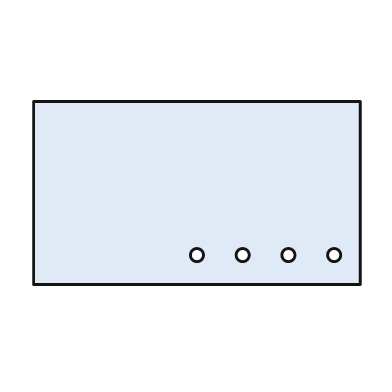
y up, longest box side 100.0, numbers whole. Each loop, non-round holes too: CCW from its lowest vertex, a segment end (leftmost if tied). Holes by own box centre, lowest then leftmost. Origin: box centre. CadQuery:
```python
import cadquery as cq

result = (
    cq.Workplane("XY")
    .moveTo(-50.0, -28.0)
    .lineTo(50.0, -28.0)
    .lineTo(50.0, 28.0)
    .lineTo(-50.0, 28.0)
    .close()
    .moveTo(0.0, -19.0)
    .circle(2.0)
    .moveTo(14.0, -19.0)
    .circle(2.0)
    .moveTo(28.0, -19.0)
    .circle(2.0)
    .moveTo(42.0, -19.0)
    .circle(2.0)
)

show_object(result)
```